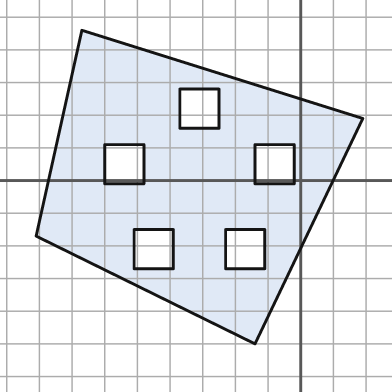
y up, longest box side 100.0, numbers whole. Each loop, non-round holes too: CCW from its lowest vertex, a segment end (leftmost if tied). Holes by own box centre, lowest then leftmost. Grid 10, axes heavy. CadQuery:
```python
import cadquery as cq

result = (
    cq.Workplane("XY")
    .moveTo(-14.0, -50.0)
    .lineTo(19.0, 19.0)
    .lineTo(-67.0, 46.0)
    .lineTo(-81.0, -17.0)
    .close()
    .moveTo(-51.0, -27.0)
    .lineTo(-39.0, -27.0)
    .lineTo(-39.0, -15.0)
    .lineTo(-51.0, -15.0)
    .close()
    .moveTo(-23.0, -27.0)
    .lineTo(-11.0, -27.0)
    .lineTo(-11.0, -15.0)
    .lineTo(-23.0, -15.0)
    .close()
    .moveTo(-60.0, -1.0)
    .lineTo(-48.0, -1.0)
    .lineTo(-48.0, 11.0)
    .lineTo(-60.0, 11.0)
    .close()
    .moveTo(-14.0, -1.0)
    .lineTo(-2.0, -1.0)
    .lineTo(-2.0, 11.0)
    .lineTo(-14.0, 11.0)
    .close()
    .moveTo(-37.0, 16.0)
    .lineTo(-25.0, 16.0)
    .lineTo(-25.0, 28.0)
    .lineTo(-37.0, 28.0)
    .close()
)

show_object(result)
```